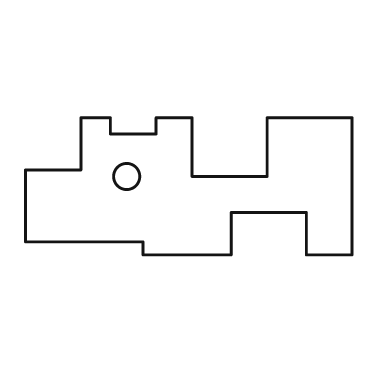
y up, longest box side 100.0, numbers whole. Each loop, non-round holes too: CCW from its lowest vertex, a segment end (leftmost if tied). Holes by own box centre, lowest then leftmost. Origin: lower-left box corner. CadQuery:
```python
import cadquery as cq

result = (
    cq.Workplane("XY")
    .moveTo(36.0, 0.0)
    .lineTo(63.0, 0.0)
    .lineTo(63.0, 13.0)
    .lineTo(86.0, 13.0)
    .lineTo(86.0, 0.0)
    .lineTo(100.0, 0.0)
    .lineTo(100.0, 42.0)
    .lineTo(74.0, 42.0)
    .lineTo(74.0, 24.0)
    .lineTo(51.0, 24.0)
    .lineTo(51.0, 42.0)
    .lineTo(40.0, 42.0)
    .lineTo(40.0, 37.0)
    .lineTo(26.0, 37.0)
    .lineTo(26.0, 42.0)
    .lineTo(17.0, 42.0)
    .lineTo(17.0, 26.0)
    .lineTo(0.0, 26.0)
    .lineTo(0.0, 4.0)
    .lineTo(36.0, 4.0)
    .close()
    .moveTo(31.0, 24.0)
    .circle(4.0)
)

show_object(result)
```